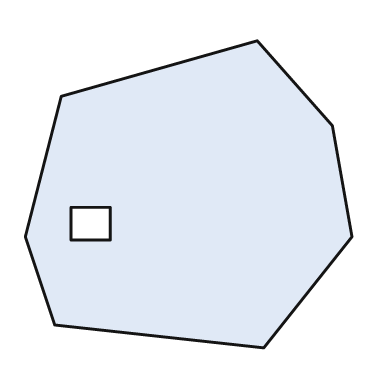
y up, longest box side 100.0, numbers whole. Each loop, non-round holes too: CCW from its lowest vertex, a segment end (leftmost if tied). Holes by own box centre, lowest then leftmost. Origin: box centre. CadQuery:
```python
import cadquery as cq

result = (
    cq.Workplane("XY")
    .moveTo(23.0, -47.0)
    .lineTo(50.0, -13.0)
    .lineTo(44.0, 21.0)
    .lineTo(21.0, 47.0)
    .lineTo(-39.0, 30.0)
    .lineTo(-50.0, -13.0)
    .lineTo(-41.0, -40.0)
    .close()
    .moveTo(-36.0, -14.0)
    .lineTo(-24.0, -14.0)
    .lineTo(-24.0, -4.0)
    .lineTo(-36.0, -4.0)
    .close()
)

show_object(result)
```